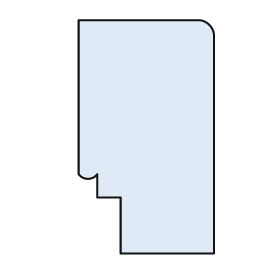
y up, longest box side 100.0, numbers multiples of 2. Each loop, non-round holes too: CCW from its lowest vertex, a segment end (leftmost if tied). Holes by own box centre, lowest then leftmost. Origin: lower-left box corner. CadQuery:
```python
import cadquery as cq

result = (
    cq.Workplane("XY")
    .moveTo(18.0, 0.0)
    .lineTo(58.0, 0.0)
    .lineTo(58.0, 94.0)
    .threePointArc((56.0, 98.0), (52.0, 100.0))
    .lineTo(0.0, 100.0)
    .lineTo(0.0, 34.0)
    .threePointArc((4.0, 32.0), (8.0, 34.0))
    .lineTo(8.0, 24.0)
    .lineTo(18.0, 24.0)
    .close()
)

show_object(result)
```